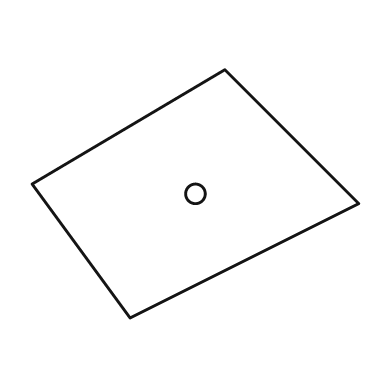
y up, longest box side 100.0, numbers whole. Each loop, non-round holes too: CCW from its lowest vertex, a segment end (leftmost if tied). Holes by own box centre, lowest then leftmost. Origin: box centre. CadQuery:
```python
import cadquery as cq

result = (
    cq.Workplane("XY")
    .moveTo(-20.0, -38.0)
    .lineTo(50.0, -3.0)
    .lineTo(9.0, 38.0)
    .lineTo(-50.0, 3.0)
    .close()
    .moveTo(0.0, 0.0)
    .circle(3.0)
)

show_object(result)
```